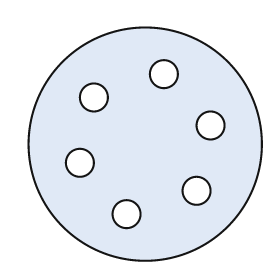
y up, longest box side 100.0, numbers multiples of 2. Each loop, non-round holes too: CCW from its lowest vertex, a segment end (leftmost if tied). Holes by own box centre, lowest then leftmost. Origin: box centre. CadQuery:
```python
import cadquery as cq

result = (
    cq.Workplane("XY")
    .moveTo(0.0, 0.0)
    .circle(50.0)
    .moveTo(-8.0, -30.0)
    .circle(6.0)
    .moveTo(22.0, -20.0)
    .circle(6.0)
    .moveTo(-28.0, -8.0)
    .circle(6.0)
    .moveTo(28.0, 8.0)
    .circle(6.0)
    .moveTo(-22.0, 20.0)
    .circle(6.0)
    .moveTo(8.0, 30.0)
    .circle(6.0)
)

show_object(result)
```